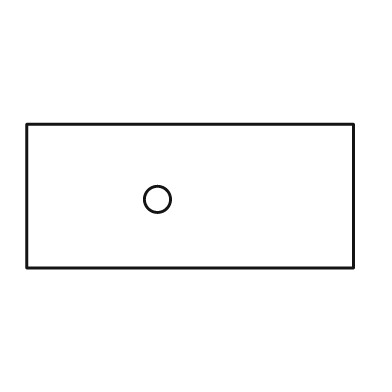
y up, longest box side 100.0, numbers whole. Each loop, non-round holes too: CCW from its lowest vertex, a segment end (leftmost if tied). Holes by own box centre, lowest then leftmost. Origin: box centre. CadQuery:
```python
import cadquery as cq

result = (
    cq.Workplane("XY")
    .moveTo(-50.0, -22.0)
    .lineTo(50.0, -22.0)
    .lineTo(50.0, 22.0)
    .lineTo(-50.0, 22.0)
    .close()
    .moveTo(-10.0, -1.0)
    .circle(4.0)
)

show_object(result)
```